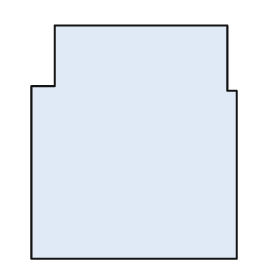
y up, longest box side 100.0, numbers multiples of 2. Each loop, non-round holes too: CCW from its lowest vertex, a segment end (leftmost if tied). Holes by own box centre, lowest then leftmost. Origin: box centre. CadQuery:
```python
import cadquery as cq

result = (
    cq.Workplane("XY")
    .moveTo(-44.0, -50.0)
    .lineTo(44.0, -50.0)
    .lineTo(44.0, 22.0)
    .lineTo(40.0, 22.0)
    .lineTo(40.0, 50.0)
    .lineTo(-34.0, 50.0)
    .lineTo(-34.0, 24.0)
    .lineTo(-44.0, 24.0)
    .close()
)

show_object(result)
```